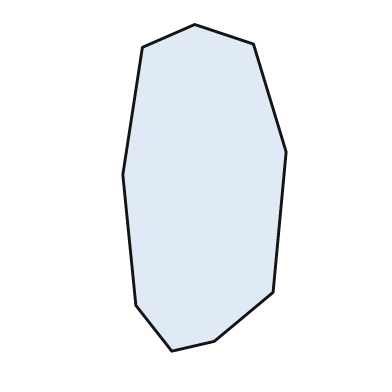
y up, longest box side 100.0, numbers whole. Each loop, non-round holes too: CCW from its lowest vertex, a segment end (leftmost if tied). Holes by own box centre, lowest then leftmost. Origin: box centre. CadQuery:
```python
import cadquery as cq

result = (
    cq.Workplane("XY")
    .moveTo(-10.0, -50.0)
    .lineTo(3.0, -47.0)
    .lineTo(21.0, -32.0)
    .lineTo(25.0, 11.0)
    .lineTo(15.0, 44.0)
    .lineTo(-3.0, 50.0)
    .lineTo(-19.0, 43.0)
    .lineTo(-25.0, 4.0)
    .lineTo(-21.0, -36.0)
    .close()
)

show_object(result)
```